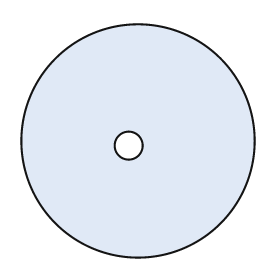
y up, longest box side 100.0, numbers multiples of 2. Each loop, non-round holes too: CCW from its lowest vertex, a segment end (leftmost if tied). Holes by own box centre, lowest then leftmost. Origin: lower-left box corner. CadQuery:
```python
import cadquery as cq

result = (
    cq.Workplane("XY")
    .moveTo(50.0, 50.0)
    .circle(50.0)
    .moveTo(46.0, 48.0)
    .circle(6.0)
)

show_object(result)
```